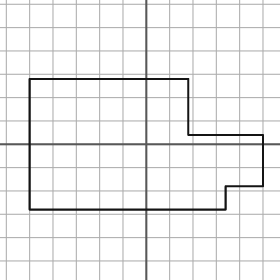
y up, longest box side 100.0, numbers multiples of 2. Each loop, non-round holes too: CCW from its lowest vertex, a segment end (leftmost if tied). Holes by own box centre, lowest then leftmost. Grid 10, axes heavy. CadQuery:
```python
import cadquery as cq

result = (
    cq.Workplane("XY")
    .moveTo(-50.0, -28.0)
    .lineTo(34.0, -28.0)
    .lineTo(34.0, -18.0)
    .lineTo(50.0, -18.0)
    .lineTo(50.0, 4.0)
    .lineTo(18.0, 4.0)
    .lineTo(18.0, 28.0)
    .lineTo(-50.0, 28.0)
    .close()
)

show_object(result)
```